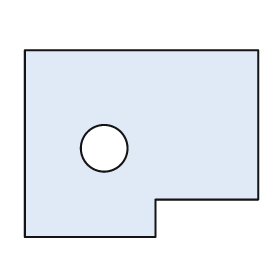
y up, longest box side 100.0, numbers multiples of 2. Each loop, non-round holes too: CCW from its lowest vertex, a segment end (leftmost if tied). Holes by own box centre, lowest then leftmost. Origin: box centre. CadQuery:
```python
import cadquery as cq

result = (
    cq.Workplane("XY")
    .moveTo(-50.0, -40.0)
    .lineTo(6.0, -40.0)
    .lineTo(6.0, -24.0)
    .lineTo(50.0, -24.0)
    .lineTo(50.0, 40.0)
    .lineTo(-50.0, 40.0)
    .close()
    .moveTo(-16.0, -2.0)
    .circle(10.0)
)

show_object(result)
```